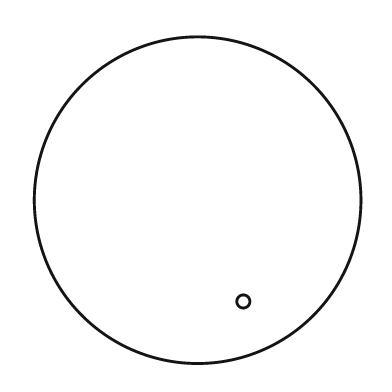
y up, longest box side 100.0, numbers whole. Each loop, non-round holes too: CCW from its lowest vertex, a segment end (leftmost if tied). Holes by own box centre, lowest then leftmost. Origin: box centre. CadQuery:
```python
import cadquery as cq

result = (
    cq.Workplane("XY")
    .moveTo(0.0, 0.0)
    .circle(50.0)
    .moveTo(14.0, -31.0)
    .circle(2.0)
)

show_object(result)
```